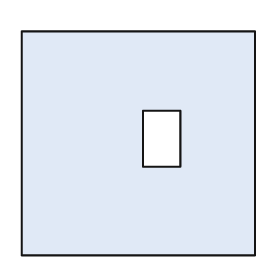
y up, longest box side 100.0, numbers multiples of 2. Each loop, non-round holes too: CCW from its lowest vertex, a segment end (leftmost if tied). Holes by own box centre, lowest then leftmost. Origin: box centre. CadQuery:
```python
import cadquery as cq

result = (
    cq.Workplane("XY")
    .moveTo(-50.0, -48.0)
    .lineTo(50.0, -48.0)
    .lineTo(50.0, 48.0)
    .lineTo(-50.0, 48.0)
    .close()
    .moveTo(2.0, -10.0)
    .lineTo(18.0, -10.0)
    .lineTo(18.0, 14.0)
    .lineTo(2.0, 14.0)
    .close()
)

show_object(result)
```